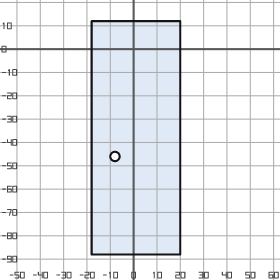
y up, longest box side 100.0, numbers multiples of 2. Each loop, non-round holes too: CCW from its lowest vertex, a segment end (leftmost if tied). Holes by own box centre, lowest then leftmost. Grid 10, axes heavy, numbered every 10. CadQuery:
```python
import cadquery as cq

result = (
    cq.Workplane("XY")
    .moveTo(-18.0, -88.0)
    .lineTo(20.0, -88.0)
    .lineTo(20.0, 12.0)
    .lineTo(-18.0, 12.0)
    .close()
    .moveTo(-8.0, -46.0)
    .circle(2.0)
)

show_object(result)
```